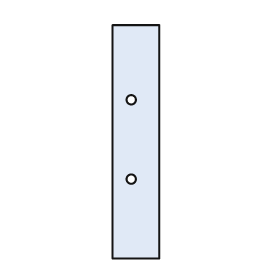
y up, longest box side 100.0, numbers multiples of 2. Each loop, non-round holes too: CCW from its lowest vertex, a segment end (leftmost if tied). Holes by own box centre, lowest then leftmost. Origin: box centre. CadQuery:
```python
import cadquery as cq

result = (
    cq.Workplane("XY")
    .moveTo(-10.0, -50.0)
    .lineTo(10.0, -50.0)
    .lineTo(10.0, 50.0)
    .lineTo(-10.0, 50.0)
    .close()
    .moveTo(-2.0, -16.0)
    .circle(2.0)
    .moveTo(-2.0, 18.0)
    .circle(2.0)
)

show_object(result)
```